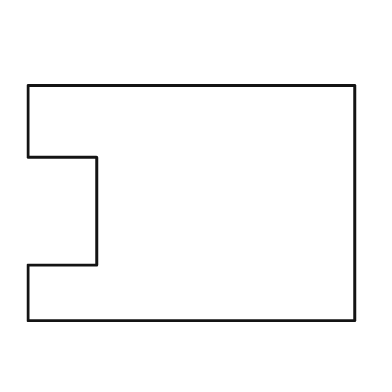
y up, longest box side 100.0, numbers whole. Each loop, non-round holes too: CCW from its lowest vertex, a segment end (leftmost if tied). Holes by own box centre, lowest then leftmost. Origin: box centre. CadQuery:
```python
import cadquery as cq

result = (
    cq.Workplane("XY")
    .moveTo(-50.0, -36.0)
    .lineTo(50.0, -36.0)
    .lineTo(50.0, 36.0)
    .lineTo(-50.0, 36.0)
    .lineTo(-50.0, 14.0)
    .lineTo(-29.0, 14.0)
    .lineTo(-29.0, -19.0)
    .lineTo(-50.0, -19.0)
    .close()
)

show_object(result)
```